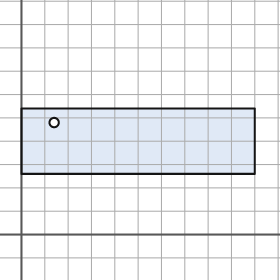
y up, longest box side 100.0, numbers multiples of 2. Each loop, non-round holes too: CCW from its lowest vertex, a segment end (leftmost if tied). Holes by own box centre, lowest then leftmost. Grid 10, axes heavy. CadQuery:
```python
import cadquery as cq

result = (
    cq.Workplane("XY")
    .moveTo(0.0, 26.0)
    .lineTo(100.0, 26.0)
    .lineTo(100.0, 54.0)
    .lineTo(0.0, 54.0)
    .close()
    .moveTo(14.0, 48.0)
    .circle(2.0)
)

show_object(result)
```